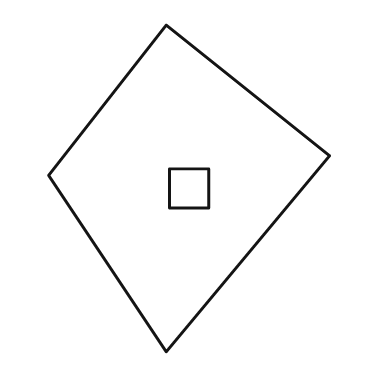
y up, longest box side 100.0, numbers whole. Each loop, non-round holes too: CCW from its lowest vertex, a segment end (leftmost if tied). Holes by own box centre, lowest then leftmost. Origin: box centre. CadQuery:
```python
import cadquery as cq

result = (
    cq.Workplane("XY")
    .moveTo(-7.0, -50.0)
    .lineTo(43.0, 10.0)
    .lineTo(-7.0, 50.0)
    .lineTo(-43.0, 4.0)
    .close()
    .moveTo(-6.0, -6.0)
    .lineTo(6.0, -6.0)
    .lineTo(6.0, 6.0)
    .lineTo(-6.0, 6.0)
    .close()
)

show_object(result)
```